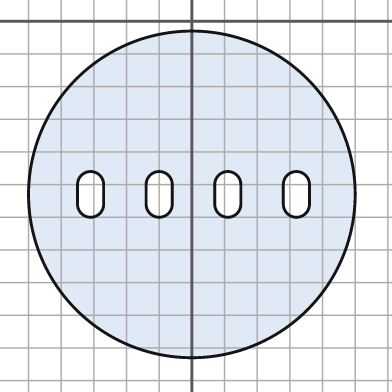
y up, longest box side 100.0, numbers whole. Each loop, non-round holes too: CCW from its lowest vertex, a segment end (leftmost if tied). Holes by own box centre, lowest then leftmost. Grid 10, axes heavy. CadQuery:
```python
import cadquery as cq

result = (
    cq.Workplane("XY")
    .moveTo(0.0, -53.0)
    .circle(50.0)
    .moveTo(-35.0, -56.0)
    .threePointArc((-31.0, -60.0), (-27.0, -56.0))
    .lineTo(-27.0, -50.0)
    .threePointArc((-31.0, -46.0), (-35.0, -50.0))
    .close()
    .moveTo(-14.0, -56.0)
    .threePointArc((-10.0, -60.0), (-6.0, -56.0))
    .lineTo(-6.0, -50.0)
    .threePointArc((-10.0, -46.0), (-14.0, -50.0))
    .close()
    .moveTo(7.0, -56.0)
    .threePointArc((11.0, -60.0), (15.0, -56.0))
    .lineTo(15.0, -50.0)
    .threePointArc((11.0, -46.0), (7.0, -50.0))
    .close()
    .moveTo(28.0, -56.0)
    .threePointArc((32.0, -60.0), (36.0, -56.0))
    .lineTo(36.0, -50.0)
    .threePointArc((32.0, -46.0), (28.0, -50.0))
    .close()
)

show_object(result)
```